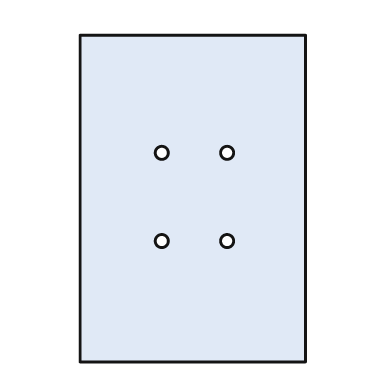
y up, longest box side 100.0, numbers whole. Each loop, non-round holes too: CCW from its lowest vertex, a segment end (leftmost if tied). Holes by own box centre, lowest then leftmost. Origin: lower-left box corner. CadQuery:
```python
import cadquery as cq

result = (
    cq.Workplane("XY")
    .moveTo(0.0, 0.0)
    .lineTo(69.0, 0.0)
    .lineTo(69.0, 100.0)
    .lineTo(0.0, 100.0)
    .close()
    .moveTo(25.0, 37.0)
    .circle(2.0)
    .moveTo(45.0, 37.0)
    .circle(2.0)
    .moveTo(25.0, 64.0)
    .circle(2.0)
    .moveTo(45.0, 64.0)
    .circle(2.0)
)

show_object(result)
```